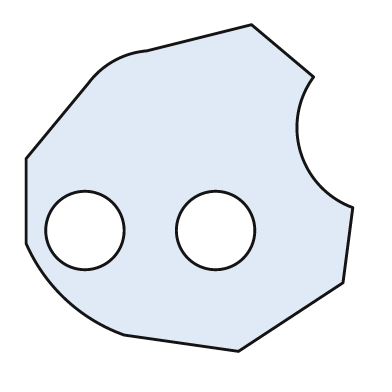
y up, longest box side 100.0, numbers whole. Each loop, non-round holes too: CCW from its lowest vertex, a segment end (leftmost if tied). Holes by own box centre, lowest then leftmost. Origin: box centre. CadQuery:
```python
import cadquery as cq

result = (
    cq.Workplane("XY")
    .moveTo(15.0, -50.0)
    .lineTo(47.0, -29.0)
    .lineTo(50.0, -6.0)
    .threePointArc((34.0, 11.0), (38.0, 34.0))
    .lineTo(19.0, 50.0)
    .lineTo(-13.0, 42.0)
    .threePointArc((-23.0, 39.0), (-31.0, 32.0))
    .lineTo(-50.0, 9.0)
    .lineTo(-50.0, -17.0)
    .threePointArc((-38.0, -34.0), (-20.0, -45.0))
    .close()
    .moveTo(-32.0, -13.0)
    .circle(12.0)
    .moveTo(8.0, -13.0)
    .circle(12.0)
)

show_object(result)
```